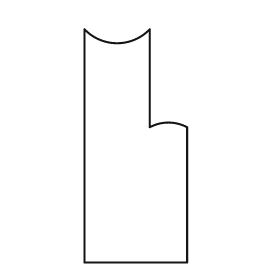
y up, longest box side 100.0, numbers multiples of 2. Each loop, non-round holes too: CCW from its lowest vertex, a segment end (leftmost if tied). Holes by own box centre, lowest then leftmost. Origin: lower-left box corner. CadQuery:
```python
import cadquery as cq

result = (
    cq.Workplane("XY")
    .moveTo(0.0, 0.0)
    .lineTo(44.0, 0.0)
    .lineTo(44.0, 58.0)
    .threePointArc((36.0, 60.0), (28.0, 58.0))
    .lineTo(28.0, 100.0)
    .threePointArc((14.0, 94.0), (0.0, 100.0))
    .close()
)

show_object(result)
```